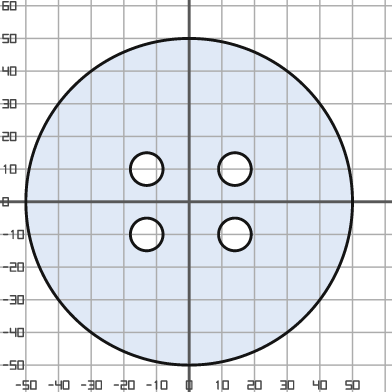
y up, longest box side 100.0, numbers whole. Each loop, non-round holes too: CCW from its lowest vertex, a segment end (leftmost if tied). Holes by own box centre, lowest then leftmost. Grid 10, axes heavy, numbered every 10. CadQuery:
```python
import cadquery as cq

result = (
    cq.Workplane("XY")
    .moveTo(0.0, 0.0)
    .circle(50.0)
    .moveTo(-13.0, -10.0)
    .circle(5.0)
    .moveTo(14.0, -10.0)
    .circle(5.0)
    .moveTo(-13.0, 10.0)
    .circle(5.0)
    .moveTo(14.0, 10.0)
    .circle(5.0)
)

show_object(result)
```